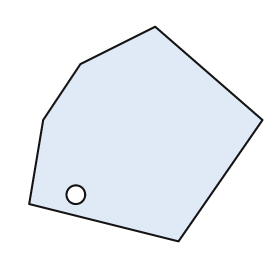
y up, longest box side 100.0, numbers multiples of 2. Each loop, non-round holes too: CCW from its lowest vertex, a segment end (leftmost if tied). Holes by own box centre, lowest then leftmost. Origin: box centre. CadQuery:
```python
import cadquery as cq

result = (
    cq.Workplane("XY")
    .moveTo(14.0, -46.0)
    .lineTo(50.0, 6.0)
    .lineTo(4.0, 46.0)
    .lineTo(-28.0, 30.0)
    .lineTo(-44.0, 6.0)
    .lineTo(-50.0, -30.0)
    .close()
    .moveTo(-30.0, -26.0)
    .circle(4.0)
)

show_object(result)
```